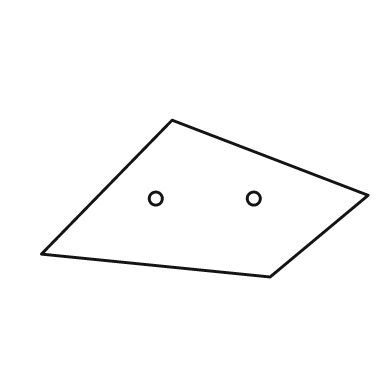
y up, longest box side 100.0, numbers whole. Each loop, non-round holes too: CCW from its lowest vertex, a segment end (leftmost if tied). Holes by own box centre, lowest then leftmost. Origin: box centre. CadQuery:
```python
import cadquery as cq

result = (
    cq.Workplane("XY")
    .moveTo(20.0, -24.0)
    .lineTo(50.0, 1.0)
    .lineTo(-10.0, 24.0)
    .lineTo(-50.0, -17.0)
    .close()
    .moveTo(-15.0, 0.0)
    .circle(2.0)
    .moveTo(15.0, 0.0)
    .circle(2.0)
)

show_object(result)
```